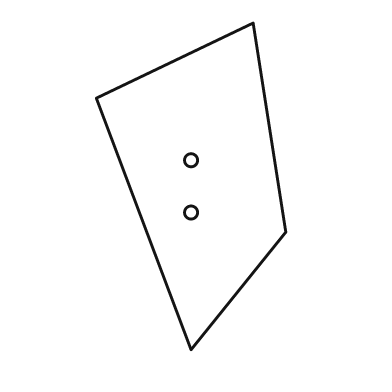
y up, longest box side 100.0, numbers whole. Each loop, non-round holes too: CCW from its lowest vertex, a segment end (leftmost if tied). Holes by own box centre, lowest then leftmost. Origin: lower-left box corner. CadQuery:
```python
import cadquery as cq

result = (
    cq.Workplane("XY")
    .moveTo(29.0, 0.0)
    .lineTo(58.0, 36.0)
    .lineTo(48.0, 100.0)
    .lineTo(0.0, 77.0)
    .close()
    .moveTo(29.0, 42.0)
    .circle(2.0)
    .moveTo(29.0, 58.0)
    .circle(2.0)
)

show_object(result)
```